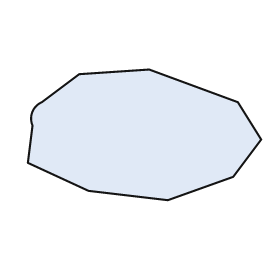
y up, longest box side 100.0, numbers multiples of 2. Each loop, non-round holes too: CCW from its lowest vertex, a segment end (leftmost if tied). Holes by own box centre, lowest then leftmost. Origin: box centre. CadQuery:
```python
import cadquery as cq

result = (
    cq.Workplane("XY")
    .moveTo(10.0, -28.0)
    .lineTo(38.0, -18.0)
    .lineTo(50.0, -2.0)
    .lineTo(40.0, 14.0)
    .lineTo(2.0, 28.0)
    .lineTo(-28.0, 26.0)
    .lineTo(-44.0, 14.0)
    .threePointArc((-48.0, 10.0), (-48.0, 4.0))
    .lineTo(-50.0, -12.0)
    .lineTo(-24.0, -24.0)
    .close()
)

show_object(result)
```